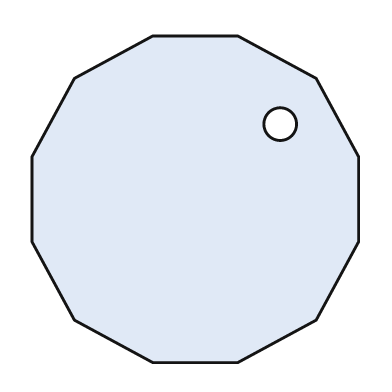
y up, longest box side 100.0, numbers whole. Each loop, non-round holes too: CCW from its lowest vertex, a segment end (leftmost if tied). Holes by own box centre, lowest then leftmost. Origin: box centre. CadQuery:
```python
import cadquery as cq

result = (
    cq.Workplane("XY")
    .moveTo(-13.0, -50.0)
    .lineTo(13.0, -50.0)
    .lineTo(37.0, -37.0)
    .lineTo(50.0, -13.0)
    .lineTo(50.0, 13.0)
    .lineTo(37.0, 37.0)
    .lineTo(13.0, 50.0)
    .lineTo(-13.0, 50.0)
    .lineTo(-37.0, 37.0)
    .lineTo(-50.0, 13.0)
    .lineTo(-50.0, -13.0)
    .lineTo(-37.0, -37.0)
    .close()
    .moveTo(26.0, 23.0)
    .circle(5.0)
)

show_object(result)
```